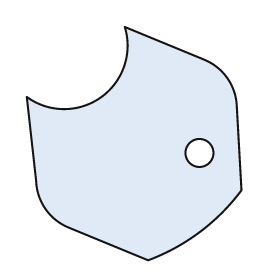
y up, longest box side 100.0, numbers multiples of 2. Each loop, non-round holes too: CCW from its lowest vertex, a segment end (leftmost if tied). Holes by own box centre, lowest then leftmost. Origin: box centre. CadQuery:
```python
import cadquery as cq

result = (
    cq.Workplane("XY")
    .moveTo(6.0, -50.0)
    .threePointArc((28.0, -38.0), (46.0, -20.0))
    .lineTo(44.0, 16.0)
    .threePointArc((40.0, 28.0), (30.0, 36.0))
    .lineTo(-4.0, 50.0)
    .threePointArc((-14.0, 20.0), (-46.0, 20.0))
    .lineTo(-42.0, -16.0)
    .threePointArc((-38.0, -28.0), (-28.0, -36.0))
    .close()
    .moveTo(28.0, -4.0)
    .circle(6.0)
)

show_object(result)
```